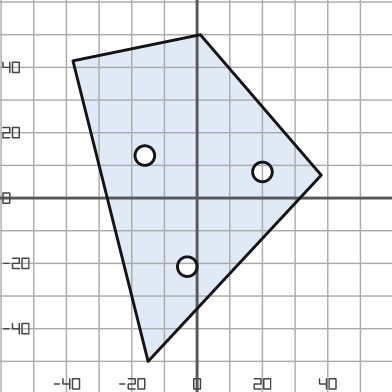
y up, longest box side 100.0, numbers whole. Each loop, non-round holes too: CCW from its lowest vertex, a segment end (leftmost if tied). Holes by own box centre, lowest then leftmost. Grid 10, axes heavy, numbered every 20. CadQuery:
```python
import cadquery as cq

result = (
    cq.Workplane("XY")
    .moveTo(-15.0, -50.0)
    .lineTo(38.0, 7.0)
    .lineTo(1.0, 50.0)
    .lineTo(-38.0, 42.0)
    .close()
    .moveTo(-3.0, -21.0)
    .circle(3.0)
    .moveTo(20.0, 8.0)
    .circle(3.0)
    .moveTo(-16.0, 13.0)
    .circle(3.0)
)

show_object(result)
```